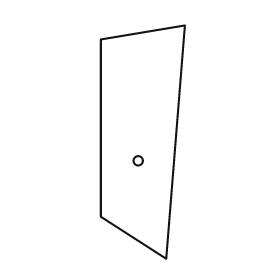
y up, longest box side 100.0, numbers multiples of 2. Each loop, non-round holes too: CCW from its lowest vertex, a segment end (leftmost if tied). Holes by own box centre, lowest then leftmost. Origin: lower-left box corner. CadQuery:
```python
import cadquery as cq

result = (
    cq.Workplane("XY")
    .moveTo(28.0, 0.0)
    .lineTo(36.0, 100.0)
    .lineTo(0.0, 94.0)
    .lineTo(0.0, 18.0)
    .close()
    .moveTo(16.0, 42.0)
    .circle(2.0)
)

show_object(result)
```